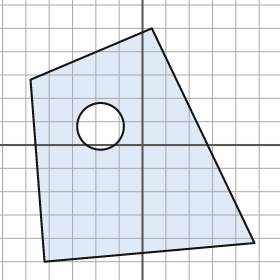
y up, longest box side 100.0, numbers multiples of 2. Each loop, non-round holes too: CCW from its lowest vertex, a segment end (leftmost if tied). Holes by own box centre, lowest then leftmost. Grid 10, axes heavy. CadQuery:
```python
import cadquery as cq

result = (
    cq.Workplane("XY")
    .moveTo(-42.0, -50.0)
    .lineTo(48.0, -42.0)
    .lineTo(4.0, 50.0)
    .lineTo(-48.0, 28.0)
    .close()
    .moveTo(-18.0, 8.0)
    .circle(10.0)
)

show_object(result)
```